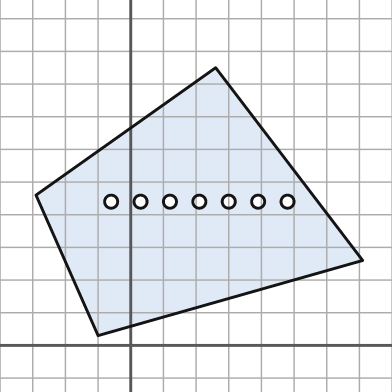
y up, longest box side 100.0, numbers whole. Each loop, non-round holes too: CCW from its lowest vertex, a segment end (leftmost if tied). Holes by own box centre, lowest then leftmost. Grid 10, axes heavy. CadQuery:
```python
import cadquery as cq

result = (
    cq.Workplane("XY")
    .moveTo(-10.0, 3.0)
    .lineTo(71.0, 26.0)
    .lineTo(26.0, 85.0)
    .lineTo(-29.0, 46.0)
    .close()
    .moveTo(-6.0, 44.0)
    .circle(2.0)
    .moveTo(3.0, 44.0)
    .circle(2.0)
    .moveTo(12.0, 44.0)
    .circle(2.0)
    .moveTo(21.0, 44.0)
    .circle(2.0)
    .moveTo(30.0, 44.0)
    .circle(2.0)
    .moveTo(39.0, 44.0)
    .circle(2.0)
    .moveTo(48.0, 44.0)
    .circle(2.0)
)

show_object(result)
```